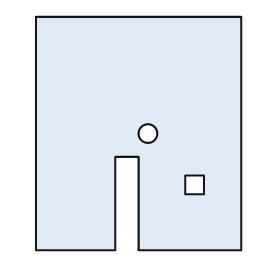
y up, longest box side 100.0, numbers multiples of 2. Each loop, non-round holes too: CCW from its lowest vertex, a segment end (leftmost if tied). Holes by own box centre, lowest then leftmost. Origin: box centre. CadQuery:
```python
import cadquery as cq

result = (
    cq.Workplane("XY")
    .moveTo(-44.0, -50.0)
    .lineTo(-10.0, -50.0)
    .lineTo(-10.0, -10.0)
    .lineTo(0.0, -10.0)
    .lineTo(0.0, -50.0)
    .lineTo(44.0, -50.0)
    .lineTo(44.0, 50.0)
    .lineTo(-44.0, 50.0)
    .close()
    .moveTo(20.0, -26.0)
    .lineTo(28.0, -26.0)
    .lineTo(28.0, -18.0)
    .lineTo(20.0, -18.0)
    .close()
    .moveTo(4.0, 0.0)
    .circle(4.0)
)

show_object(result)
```